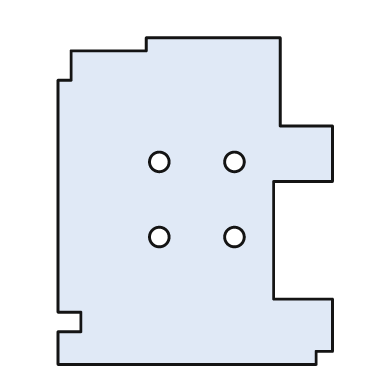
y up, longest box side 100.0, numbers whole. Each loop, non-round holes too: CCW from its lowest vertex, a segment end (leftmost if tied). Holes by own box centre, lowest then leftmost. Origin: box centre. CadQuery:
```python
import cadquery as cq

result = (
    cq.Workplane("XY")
    .moveTo(-42.0, -50.0)
    .lineTo(37.0, -50.0)
    .lineTo(37.0, -46.0)
    .lineTo(42.0, -46.0)
    .lineTo(42.0, -30.0)
    .lineTo(24.0, -30.0)
    .lineTo(24.0, 6.0)
    .lineTo(42.0, 6.0)
    .lineTo(42.0, 23.0)
    .lineTo(26.0, 23.0)
    .lineTo(26.0, 50.0)
    .lineTo(-15.0, 50.0)
    .lineTo(-15.0, 46.0)
    .lineTo(-38.0, 46.0)
    .lineTo(-38.0, 37.0)
    .lineTo(-42.0, 37.0)
    .lineTo(-42.0, -34.0)
    .lineTo(-35.0, -34.0)
    .lineTo(-35.0, -40.0)
    .lineTo(-42.0, -40.0)
    .close()
    .moveTo(-11.0, -11.0)
    .circle(3.0)
    .moveTo(12.0, -11.0)
    .circle(3.0)
    .moveTo(-11.0, 12.0)
    .circle(3.0)
    .moveTo(12.0, 12.0)
    .circle(3.0)
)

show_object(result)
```